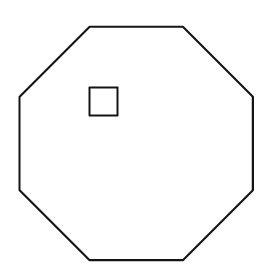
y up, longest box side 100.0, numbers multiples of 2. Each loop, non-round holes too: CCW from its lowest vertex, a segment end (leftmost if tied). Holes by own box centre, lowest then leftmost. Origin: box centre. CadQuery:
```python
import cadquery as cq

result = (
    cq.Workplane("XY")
    .moveTo(-20.0, -50.0)
    .lineTo(20.0, -50.0)
    .lineTo(50.0, -20.0)
    .lineTo(50.0, 20.0)
    .lineTo(20.0, 50.0)
    .lineTo(-20.0, 50.0)
    .lineTo(-50.0, 20.0)
    .lineTo(-50.0, -20.0)
    .close()
    .moveTo(-20.0, 12.0)
    .lineTo(-8.0, 12.0)
    .lineTo(-8.0, 24.0)
    .lineTo(-20.0, 24.0)
    .close()
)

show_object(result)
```